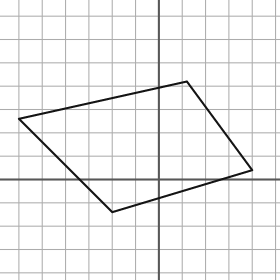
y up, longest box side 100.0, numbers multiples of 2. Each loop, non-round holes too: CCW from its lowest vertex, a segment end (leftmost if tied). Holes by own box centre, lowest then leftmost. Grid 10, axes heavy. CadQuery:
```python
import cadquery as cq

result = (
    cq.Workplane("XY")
    .moveTo(-20.0, -14.0)
    .lineTo(40.0, 4.0)
    .lineTo(12.0, 42.0)
    .lineTo(-60.0, 26.0)
    .close()
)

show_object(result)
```